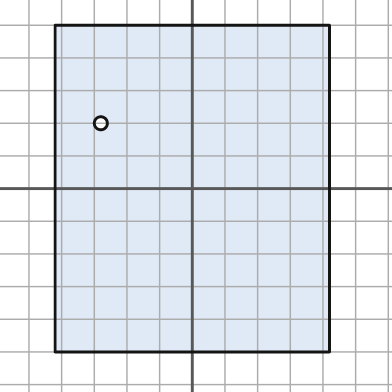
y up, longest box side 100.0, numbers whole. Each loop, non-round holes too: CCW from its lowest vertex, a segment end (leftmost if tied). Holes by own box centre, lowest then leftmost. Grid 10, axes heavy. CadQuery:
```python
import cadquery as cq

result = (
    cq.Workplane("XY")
    .moveTo(-42.0, -50.0)
    .lineTo(42.0, -50.0)
    .lineTo(42.0, 50.0)
    .lineTo(-42.0, 50.0)
    .close()
    .moveTo(-28.0, 20.0)
    .circle(2.0)
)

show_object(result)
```